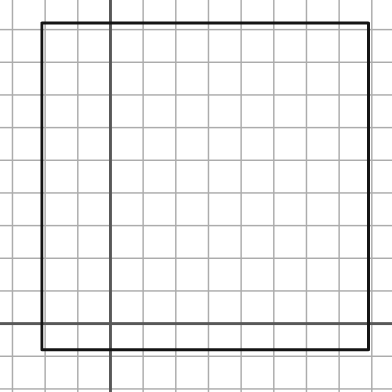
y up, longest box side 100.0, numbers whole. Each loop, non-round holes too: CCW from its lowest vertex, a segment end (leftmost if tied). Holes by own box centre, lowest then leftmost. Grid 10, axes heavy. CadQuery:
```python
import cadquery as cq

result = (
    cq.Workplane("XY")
    .moveTo(-21.0, -8.0)
    .lineTo(79.0, -8.0)
    .lineTo(79.0, 92.0)
    .lineTo(-21.0, 92.0)
    .close()
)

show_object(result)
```